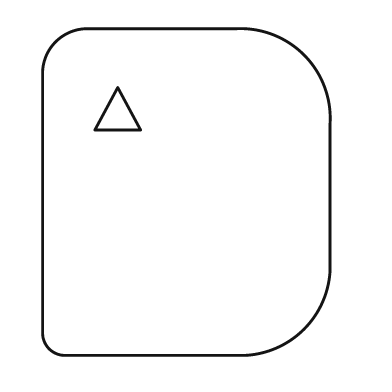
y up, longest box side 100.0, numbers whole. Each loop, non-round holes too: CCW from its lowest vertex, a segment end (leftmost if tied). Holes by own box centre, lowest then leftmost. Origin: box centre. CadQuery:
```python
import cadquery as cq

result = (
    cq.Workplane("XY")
    .moveTo(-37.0, -50.0)
    .lineTo(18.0, -50.0)
    .threePointArc((36.0, -42.0), (44.0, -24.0))
    .lineTo(44.0, 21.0)
    .threePointArc((36.0, 42.0), (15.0, 50.0))
    .lineTo(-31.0, 50.0)
    .threePointArc((-40.0, 46.0), (-44.0, 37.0))
    .lineTo(-44.0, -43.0)
    .threePointArc((-42.0, -48.0), (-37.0, -50.0))
    .close()
    .moveTo(-28.0, 19.0)
    .lineTo(-14.0, 19.0)
    .lineTo(-21.0, 32.0)
    .close()
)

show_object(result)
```